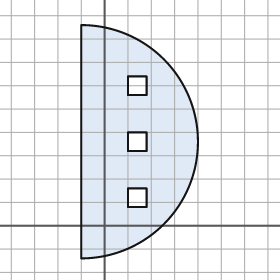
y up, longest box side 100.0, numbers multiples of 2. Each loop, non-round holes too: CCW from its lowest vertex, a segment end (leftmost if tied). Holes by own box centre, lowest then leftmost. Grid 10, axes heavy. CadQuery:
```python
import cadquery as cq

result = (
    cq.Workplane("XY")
    .moveTo(-10.0, -14.0)
    .threePointArc((40.0, 36.0), (-10.0, 86.0))
    .close()
    .moveTo(10.0, 8.0)
    .lineTo(18.0, 8.0)
    .lineTo(18.0, 16.0)
    .lineTo(10.0, 16.0)
    .close()
    .moveTo(10.0, 32.0)
    .lineTo(18.0, 32.0)
    .lineTo(18.0, 40.0)
    .lineTo(10.0, 40.0)
    .close()
    .moveTo(10.0, 56.0)
    .lineTo(18.0, 56.0)
    .lineTo(18.0, 64.0)
    .lineTo(10.0, 64.0)
    .close()
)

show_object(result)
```